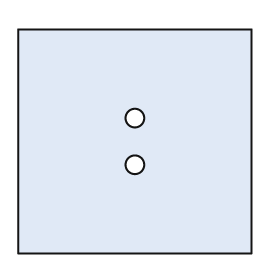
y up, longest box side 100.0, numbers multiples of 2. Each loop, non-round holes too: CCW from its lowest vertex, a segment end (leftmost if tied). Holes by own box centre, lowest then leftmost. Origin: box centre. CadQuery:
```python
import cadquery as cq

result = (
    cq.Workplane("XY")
    .moveTo(-50.0, -48.0)
    .lineTo(50.0, -48.0)
    .lineTo(50.0, 48.0)
    .lineTo(-50.0, 48.0)
    .close()
    .moveTo(0.0, -10.0)
    .circle(4.0)
    .moveTo(0.0, 10.0)
    .circle(4.0)
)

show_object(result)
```